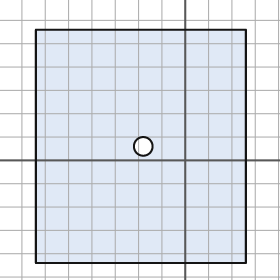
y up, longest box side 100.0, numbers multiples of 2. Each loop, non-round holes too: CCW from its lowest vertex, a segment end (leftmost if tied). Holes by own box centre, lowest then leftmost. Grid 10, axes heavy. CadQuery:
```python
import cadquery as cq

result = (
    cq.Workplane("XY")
    .moveTo(-64.0, -44.0)
    .lineTo(26.0, -44.0)
    .lineTo(26.0, 56.0)
    .lineTo(-64.0, 56.0)
    .close()
    .moveTo(-18.0, 6.0)
    .circle(4.0)
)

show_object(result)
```